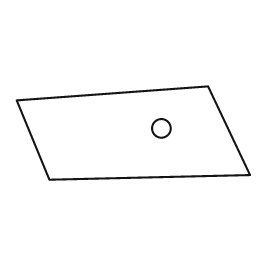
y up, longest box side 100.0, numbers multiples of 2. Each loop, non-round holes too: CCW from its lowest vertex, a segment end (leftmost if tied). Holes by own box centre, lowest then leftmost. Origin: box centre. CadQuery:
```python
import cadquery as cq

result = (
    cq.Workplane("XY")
    .moveTo(-36.0, -20.0)
    .lineTo(50.0, -18.0)
    .lineTo(32.0, 20.0)
    .lineTo(-50.0, 14.0)
    .close()
    .moveTo(12.0, 2.0)
    .circle(4.0)
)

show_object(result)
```